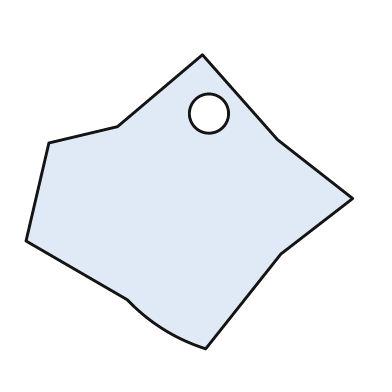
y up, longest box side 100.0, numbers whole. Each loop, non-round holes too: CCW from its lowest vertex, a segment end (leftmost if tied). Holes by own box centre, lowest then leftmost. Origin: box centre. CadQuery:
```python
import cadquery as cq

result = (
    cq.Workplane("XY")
    .moveTo(5.0, -45.0)
    .lineTo(28.0, -16.0)
    .lineTo(50.0, 1.0)
    .lineTo(27.0, 19.0)
    .lineTo(4.0, 45.0)
    .lineTo(-22.0, 23.0)
    .lineTo(-43.0, 18.0)
    .lineTo(-50.0, -12.0)
    .lineTo(-19.0, -30.0)
    .threePointArc((-8.0, -39.0), (5.0, -45.0))
    .close()
    .moveTo(6.0, 27.0)
    .circle(6.0)
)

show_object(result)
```